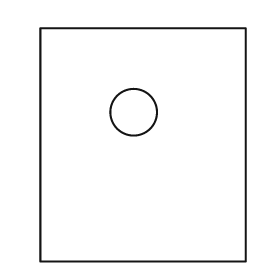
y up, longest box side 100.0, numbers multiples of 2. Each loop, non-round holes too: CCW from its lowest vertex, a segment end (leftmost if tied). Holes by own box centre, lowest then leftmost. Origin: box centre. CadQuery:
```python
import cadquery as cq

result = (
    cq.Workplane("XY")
    .moveTo(-44.0, -50.0)
    .lineTo(44.0, -50.0)
    .lineTo(44.0, 50.0)
    .lineTo(-44.0, 50.0)
    .close()
    .moveTo(-4.0, 14.0)
    .circle(10.0)
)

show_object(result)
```